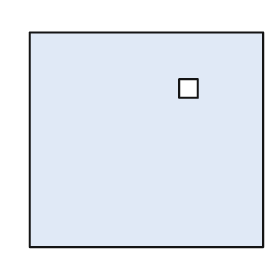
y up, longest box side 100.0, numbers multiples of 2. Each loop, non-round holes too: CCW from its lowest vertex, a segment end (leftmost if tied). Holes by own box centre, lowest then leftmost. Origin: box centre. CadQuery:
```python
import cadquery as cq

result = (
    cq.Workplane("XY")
    .moveTo(-50.0, -46.0)
    .lineTo(50.0, -46.0)
    .lineTo(50.0, 46.0)
    .lineTo(-50.0, 46.0)
    .close()
    .moveTo(14.0, 18.0)
    .lineTo(22.0, 18.0)
    .lineTo(22.0, 26.0)
    .lineTo(14.0, 26.0)
    .close()
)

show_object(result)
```